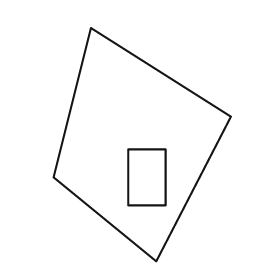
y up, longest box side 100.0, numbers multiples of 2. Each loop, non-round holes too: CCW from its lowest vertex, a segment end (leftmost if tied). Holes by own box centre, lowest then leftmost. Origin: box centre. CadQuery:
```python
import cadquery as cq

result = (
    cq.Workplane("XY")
    .moveTo(6.0, -50.0)
    .lineTo(38.0, 12.0)
    .lineTo(-22.0, 50.0)
    .lineTo(-38.0, -14.0)
    .close()
    .moveTo(-6.0, -26.0)
    .lineTo(10.0, -26.0)
    .lineTo(10.0, -2.0)
    .lineTo(-6.0, -2.0)
    .close()
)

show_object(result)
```